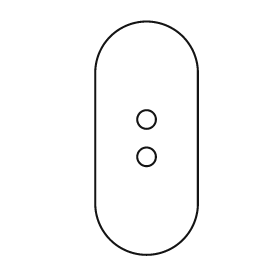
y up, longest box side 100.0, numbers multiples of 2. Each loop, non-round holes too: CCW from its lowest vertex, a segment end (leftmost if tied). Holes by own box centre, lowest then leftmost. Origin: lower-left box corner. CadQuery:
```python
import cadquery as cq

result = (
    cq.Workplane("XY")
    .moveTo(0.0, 22.0)
    .threePointArc((22.0, 0.0), (44.0, 22.0))
    .lineTo(44.0, 78.0)
    .threePointArc((22.0, 100.0), (0.0, 78.0))
    .close()
    .moveTo(22.0, 42.0)
    .circle(4.0)
    .moveTo(22.0, 58.0)
    .circle(4.0)
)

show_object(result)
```